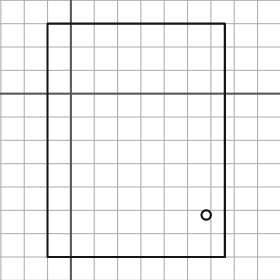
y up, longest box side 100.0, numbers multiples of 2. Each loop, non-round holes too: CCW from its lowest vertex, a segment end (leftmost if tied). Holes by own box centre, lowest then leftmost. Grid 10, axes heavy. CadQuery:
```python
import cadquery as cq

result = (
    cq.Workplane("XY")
    .moveTo(-10.0, -70.0)
    .lineTo(66.0, -70.0)
    .lineTo(66.0, 30.0)
    .lineTo(-10.0, 30.0)
    .close()
    .moveTo(58.0, -52.0)
    .circle(2.0)
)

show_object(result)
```